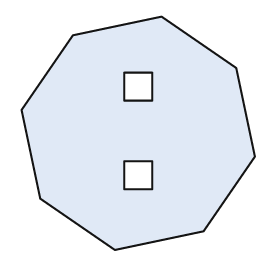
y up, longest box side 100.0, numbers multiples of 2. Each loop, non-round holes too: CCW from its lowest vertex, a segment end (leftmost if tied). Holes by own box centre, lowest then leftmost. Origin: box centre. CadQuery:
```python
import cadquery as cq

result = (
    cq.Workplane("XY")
    .moveTo(-10.0, -50.0)
    .lineTo(28.0, -42.0)
    .lineTo(50.0, -10.0)
    .lineTo(42.0, 28.0)
    .lineTo(10.0, 50.0)
    .lineTo(-28.0, 42.0)
    .lineTo(-50.0, 10.0)
    .lineTo(-42.0, -28.0)
    .close()
    .moveTo(-6.0, -24.0)
    .lineTo(6.0, -24.0)
    .lineTo(6.0, -12.0)
    .lineTo(-6.0, -12.0)
    .close()
    .moveTo(-6.0, 14.0)
    .lineTo(6.0, 14.0)
    .lineTo(6.0, 26.0)
    .lineTo(-6.0, 26.0)
    .close()
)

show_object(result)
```